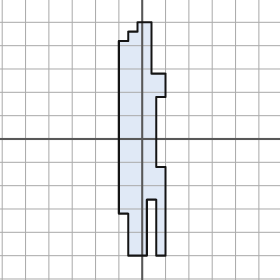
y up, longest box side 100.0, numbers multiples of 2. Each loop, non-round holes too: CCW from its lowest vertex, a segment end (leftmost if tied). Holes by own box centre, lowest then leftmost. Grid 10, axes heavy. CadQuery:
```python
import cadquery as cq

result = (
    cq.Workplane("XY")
    .moveTo(-6.0, -50.0)
    .lineTo(2.0, -50.0)
    .lineTo(2.0, -26.0)
    .lineTo(6.0, -26.0)
    .lineTo(6.0, -50.0)
    .lineTo(10.0, -50.0)
    .lineTo(10.0, -12.0)
    .lineTo(6.0, -12.0)
    .lineTo(6.0, 18.0)
    .lineTo(10.0, 18.0)
    .lineTo(10.0, 28.0)
    .lineTo(4.0, 28.0)
    .lineTo(4.0, 50.0)
    .lineTo(-2.0, 50.0)
    .lineTo(-2.0, 46.0)
    .lineTo(-6.0, 46.0)
    .lineTo(-6.0, 42.0)
    .lineTo(-10.0, 42.0)
    .lineTo(-10.0, -32.0)
    .lineTo(-6.0, -32.0)
    .close()
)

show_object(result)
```